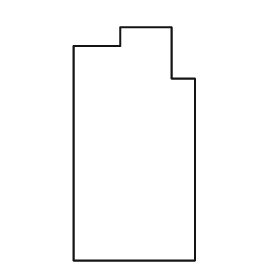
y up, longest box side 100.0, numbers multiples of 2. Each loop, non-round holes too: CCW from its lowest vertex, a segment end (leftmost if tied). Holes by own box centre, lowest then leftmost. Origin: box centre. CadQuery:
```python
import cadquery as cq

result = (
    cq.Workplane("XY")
    .moveTo(-26.0, -50.0)
    .lineTo(26.0, -50.0)
    .lineTo(26.0, 28.0)
    .lineTo(16.0, 28.0)
    .lineTo(16.0, 50.0)
    .lineTo(-6.0, 50.0)
    .lineTo(-6.0, 42.0)
    .lineTo(-26.0, 42.0)
    .close()
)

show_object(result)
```